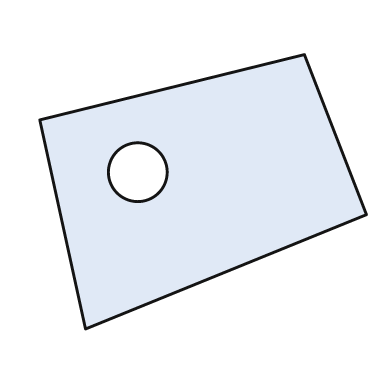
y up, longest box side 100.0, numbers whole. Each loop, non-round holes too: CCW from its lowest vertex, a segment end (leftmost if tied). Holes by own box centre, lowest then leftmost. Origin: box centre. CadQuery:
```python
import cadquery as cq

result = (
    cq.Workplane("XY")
    .moveTo(-36.0, -42.0)
    .lineTo(50.0, -7.0)
    .lineTo(31.0, 42.0)
    .lineTo(-50.0, 22.0)
    .close()
    .moveTo(-20.0, 6.0)
    .circle(9.0)
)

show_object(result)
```